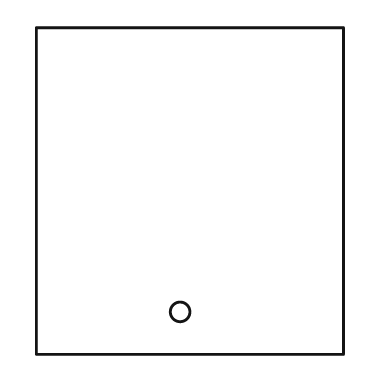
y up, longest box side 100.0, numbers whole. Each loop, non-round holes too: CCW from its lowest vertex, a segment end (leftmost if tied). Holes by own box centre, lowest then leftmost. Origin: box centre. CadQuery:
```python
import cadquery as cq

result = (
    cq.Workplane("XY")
    .moveTo(-47.0, -50.0)
    .lineTo(47.0, -50.0)
    .lineTo(47.0, 50.0)
    .lineTo(-47.0, 50.0)
    .close()
    .moveTo(-3.0, -37.0)
    .circle(3.0)
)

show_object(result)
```